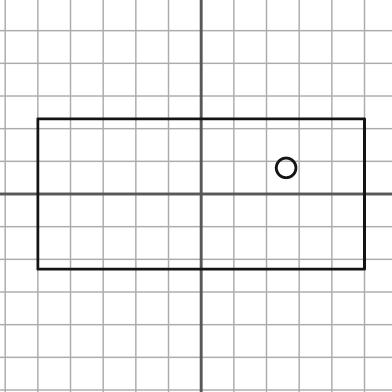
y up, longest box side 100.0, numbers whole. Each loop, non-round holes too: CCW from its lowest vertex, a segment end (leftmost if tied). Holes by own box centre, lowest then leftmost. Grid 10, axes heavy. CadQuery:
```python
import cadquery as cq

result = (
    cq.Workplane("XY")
    .moveTo(-50.0, -23.0)
    .lineTo(50.0, -23.0)
    .lineTo(50.0, 23.0)
    .lineTo(-50.0, 23.0)
    .close()
    .moveTo(26.0, 8.0)
    .circle(3.0)
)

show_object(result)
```